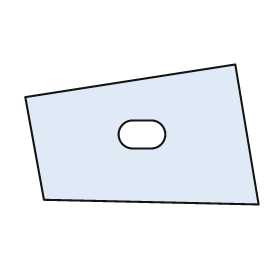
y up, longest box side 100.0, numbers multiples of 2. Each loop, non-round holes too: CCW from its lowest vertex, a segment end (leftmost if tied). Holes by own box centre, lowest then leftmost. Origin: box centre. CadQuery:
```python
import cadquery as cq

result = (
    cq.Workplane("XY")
    .moveTo(50.0, -30.0)
    .lineTo(40.0, 30.0)
    .lineTo(-50.0, 16.0)
    .lineTo(-42.0, -28.0)
    .close()
    .moveTo(-4.0, -6.0)
    .lineTo(4.0, -6.0)
    .threePointArc((10.0, 0.0), (4.0, 6.0))
    .lineTo(-4.0, 6.0)
    .threePointArc((-10.0, 0.0), (-4.0, -6.0))
    .close()
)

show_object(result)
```